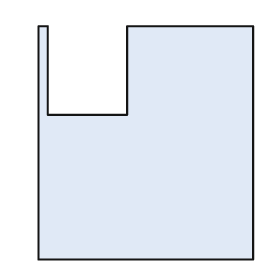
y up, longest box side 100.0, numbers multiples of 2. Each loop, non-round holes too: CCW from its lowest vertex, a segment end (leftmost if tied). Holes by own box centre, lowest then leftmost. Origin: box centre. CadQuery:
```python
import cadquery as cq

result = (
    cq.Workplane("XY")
    .moveTo(-46.0, -50.0)
    .lineTo(46.0, -50.0)
    .lineTo(46.0, 50.0)
    .lineTo(-8.0, 50.0)
    .lineTo(-8.0, 12.0)
    .lineTo(-42.0, 12.0)
    .lineTo(-42.0, 50.0)
    .lineTo(-46.0, 50.0)
    .close()
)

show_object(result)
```